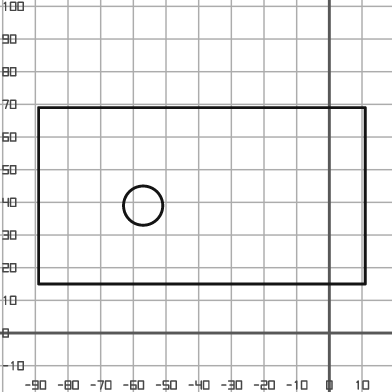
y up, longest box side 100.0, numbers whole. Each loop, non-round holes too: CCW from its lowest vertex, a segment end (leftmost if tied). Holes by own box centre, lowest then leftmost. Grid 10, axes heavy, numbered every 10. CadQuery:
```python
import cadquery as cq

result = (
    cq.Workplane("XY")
    .moveTo(-89.0, 15.0)
    .lineTo(11.0, 15.0)
    .lineTo(11.0, 69.0)
    .lineTo(-89.0, 69.0)
    .close()
    .moveTo(-57.0, 39.0)
    .circle(6.0)
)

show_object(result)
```